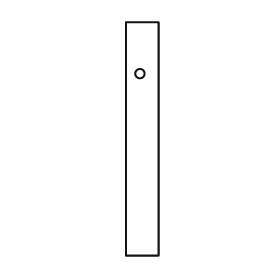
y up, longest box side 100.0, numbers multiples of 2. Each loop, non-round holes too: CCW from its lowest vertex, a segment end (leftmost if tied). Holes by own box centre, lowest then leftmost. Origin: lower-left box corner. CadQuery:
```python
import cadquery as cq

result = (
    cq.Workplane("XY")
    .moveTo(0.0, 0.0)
    .lineTo(14.0, 0.0)
    .lineTo(14.0, 100.0)
    .lineTo(0.0, 100.0)
    .close()
    .moveTo(6.0, 78.0)
    .circle(2.0)
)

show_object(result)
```